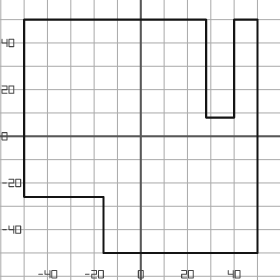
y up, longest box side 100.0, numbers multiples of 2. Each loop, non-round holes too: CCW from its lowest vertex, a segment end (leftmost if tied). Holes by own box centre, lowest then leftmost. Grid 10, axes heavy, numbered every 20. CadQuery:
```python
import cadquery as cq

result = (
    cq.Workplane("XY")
    .moveTo(-16.0, -50.0)
    .lineTo(50.0, -50.0)
    .lineTo(50.0, 50.0)
    .lineTo(40.0, 50.0)
    .lineTo(40.0, 8.0)
    .lineTo(28.0, 8.0)
    .lineTo(28.0, 50.0)
    .lineTo(-50.0, 50.0)
    .lineTo(-50.0, -26.0)
    .lineTo(-16.0, -26.0)
    .close()
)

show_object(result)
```